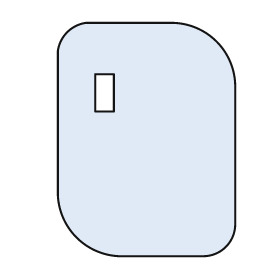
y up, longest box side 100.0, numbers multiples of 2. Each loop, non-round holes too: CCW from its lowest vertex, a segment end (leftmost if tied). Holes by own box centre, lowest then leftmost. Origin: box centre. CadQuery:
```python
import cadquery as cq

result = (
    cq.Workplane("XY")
    .moveTo(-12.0, -50.0)
    .lineTo(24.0, -50.0)
    .threePointArc((34.0, -46.0), (38.0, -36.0))
    .lineTo(38.0, 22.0)
    .threePointArc((30.0, 42.0), (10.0, 50.0))
    .lineTo(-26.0, 50.0)
    .threePointArc((-34.0, 46.0), (-38.0, 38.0))
    .lineTo(-38.0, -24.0)
    .threePointArc((-30.0, -42.0), (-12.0, -50.0))
    .close()
    .moveTo(-22.0, 12.0)
    .lineTo(-14.0, 12.0)
    .lineTo(-14.0, 28.0)
    .lineTo(-22.0, 28.0)
    .close()
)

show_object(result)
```